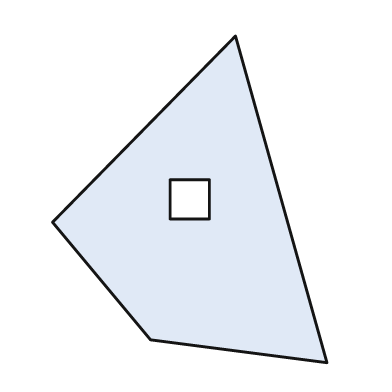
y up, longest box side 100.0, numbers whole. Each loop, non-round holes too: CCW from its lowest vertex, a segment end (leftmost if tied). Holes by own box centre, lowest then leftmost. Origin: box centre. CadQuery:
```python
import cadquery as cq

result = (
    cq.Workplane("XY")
    .moveTo(42.0, -50.0)
    .lineTo(14.0, 50.0)
    .lineTo(-42.0, -7.0)
    .lineTo(-12.0, -43.0)
    .close()
    .moveTo(-6.0, -6.0)
    .lineTo(6.0, -6.0)
    .lineTo(6.0, 6.0)
    .lineTo(-6.0, 6.0)
    .close()
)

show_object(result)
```